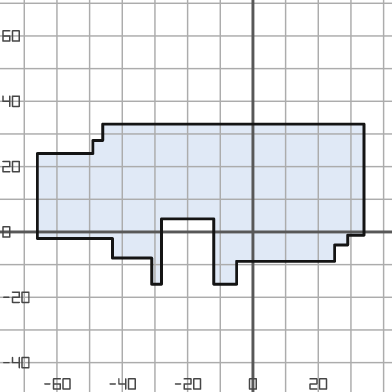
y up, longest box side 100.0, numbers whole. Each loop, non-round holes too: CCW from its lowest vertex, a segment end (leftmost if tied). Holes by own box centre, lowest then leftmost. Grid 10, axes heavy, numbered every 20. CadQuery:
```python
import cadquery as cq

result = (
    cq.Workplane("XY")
    .moveTo(-31.0, -16.0)
    .lineTo(-28.0, -16.0)
    .lineTo(-28.0, 4.0)
    .lineTo(-12.0, 4.0)
    .lineTo(-12.0, -16.0)
    .lineTo(-5.0, -16.0)
    .lineTo(-5.0, -9.0)
    .lineTo(25.0, -9.0)
    .lineTo(25.0, -4.0)
    .lineTo(29.0, -4.0)
    .lineTo(29.0, -1.0)
    .lineTo(34.0, -1.0)
    .lineTo(34.0, 33.0)
    .lineTo(-46.0, 33.0)
    .lineTo(-46.0, 28.0)
    .lineTo(-49.0, 28.0)
    .lineTo(-49.0, 24.0)
    .lineTo(-66.0, 24.0)
    .lineTo(-66.0, -2.0)
    .lineTo(-43.0, -2.0)
    .lineTo(-43.0, -8.0)
    .lineTo(-31.0, -8.0)
    .close()
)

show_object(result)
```